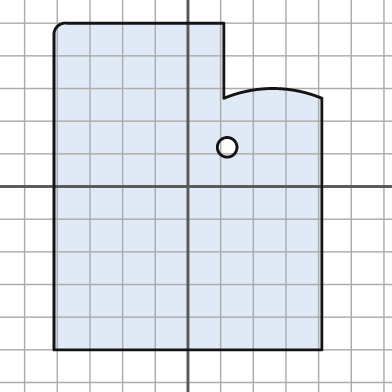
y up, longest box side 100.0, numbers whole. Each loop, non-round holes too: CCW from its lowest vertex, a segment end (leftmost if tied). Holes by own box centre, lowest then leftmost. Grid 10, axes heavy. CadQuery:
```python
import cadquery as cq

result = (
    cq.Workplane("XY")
    .moveTo(-41.0, -50.0)
    .lineTo(41.0, -50.0)
    .lineTo(41.0, 27.0)
    .threePointArc((26.0, 30.0), (11.0, 27.0))
    .lineTo(11.0, 50.0)
    .lineTo(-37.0, 50.0)
    .threePointArc((-40.0, 49.0), (-41.0, 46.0))
    .close()
    .moveTo(12.0, 12.0)
    .circle(3.0)
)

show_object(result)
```